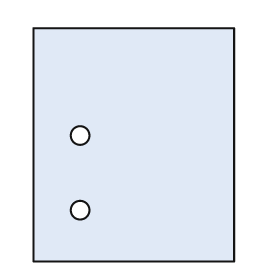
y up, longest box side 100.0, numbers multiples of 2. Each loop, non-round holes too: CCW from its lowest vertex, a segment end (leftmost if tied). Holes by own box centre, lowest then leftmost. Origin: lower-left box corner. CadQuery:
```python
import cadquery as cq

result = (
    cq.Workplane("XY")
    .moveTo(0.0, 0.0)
    .lineTo(86.0, 0.0)
    .lineTo(86.0, 100.0)
    .lineTo(0.0, 100.0)
    .close()
    .moveTo(20.0, 22.0)
    .circle(4.0)
    .moveTo(20.0, 54.0)
    .circle(4.0)
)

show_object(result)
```